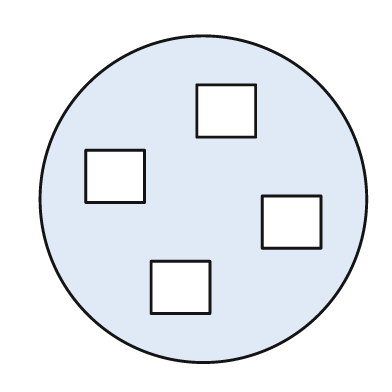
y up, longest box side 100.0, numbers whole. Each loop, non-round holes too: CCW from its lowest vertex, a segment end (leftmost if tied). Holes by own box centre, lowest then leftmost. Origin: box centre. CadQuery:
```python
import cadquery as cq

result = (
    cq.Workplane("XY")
    .moveTo(0.0, 0.0)
    .circle(50.0)
    .moveTo(-16.0, -35.0)
    .lineTo(2.0, -35.0)
    .lineTo(2.0, -19.0)
    .lineTo(-16.0, -19.0)
    .close()
    .moveTo(18.0, -15.0)
    .lineTo(36.0, -15.0)
    .lineTo(36.0, 1.0)
    .lineTo(18.0, 1.0)
    .close()
    .moveTo(-36.0, -1.0)
    .lineTo(-18.0, -1.0)
    .lineTo(-18.0, 15.0)
    .lineTo(-36.0, 15.0)
    .close()
    .moveTo(-2.0, 19.0)
    .lineTo(16.0, 19.0)
    .lineTo(16.0, 35.0)
    .lineTo(-2.0, 35.0)
    .close()
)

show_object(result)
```